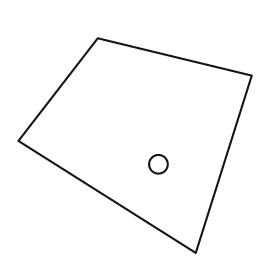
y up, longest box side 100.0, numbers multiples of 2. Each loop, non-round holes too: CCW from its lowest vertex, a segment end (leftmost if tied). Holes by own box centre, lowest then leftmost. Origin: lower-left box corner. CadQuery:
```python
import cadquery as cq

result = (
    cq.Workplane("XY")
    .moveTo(76.0, 0.0)
    .lineTo(100.0, 76.0)
    .lineTo(34.0, 92.0)
    .lineTo(0.0, 48.0)
    .close()
    .moveTo(60.0, 38.0)
    .circle(4.0)
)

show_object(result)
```